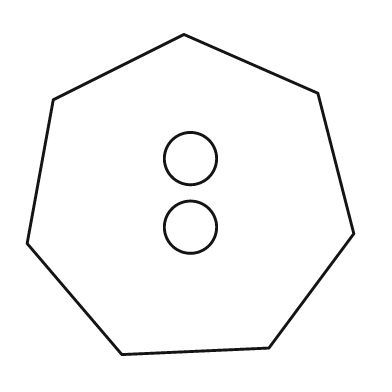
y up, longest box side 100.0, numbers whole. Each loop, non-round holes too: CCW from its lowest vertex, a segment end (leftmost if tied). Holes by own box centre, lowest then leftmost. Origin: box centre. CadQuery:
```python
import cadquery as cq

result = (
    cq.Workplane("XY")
    .moveTo(-21.0, -49.0)
    .lineTo(24.0, -47.0)
    .lineTo(50.0, -12.0)
    .lineTo(39.0, 31.0)
    .lineTo(-2.0, 49.0)
    .lineTo(-42.0, 29.0)
    .lineTo(-50.0, -15.0)
    .close()
    .moveTo(0.0, -10.0)
    .circle(8.0)
    .moveTo(0.0, 11.0)
    .circle(8.0)
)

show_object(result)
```